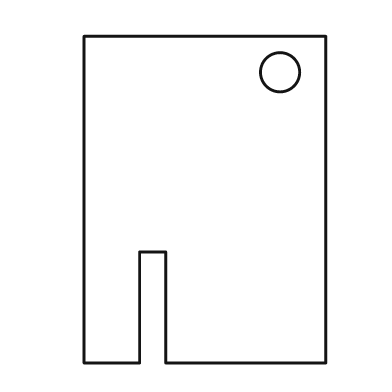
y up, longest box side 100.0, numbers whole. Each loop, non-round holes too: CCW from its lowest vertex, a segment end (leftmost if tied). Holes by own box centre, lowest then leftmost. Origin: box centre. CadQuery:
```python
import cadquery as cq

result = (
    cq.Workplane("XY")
    .moveTo(-37.0, -50.0)
    .lineTo(-20.0, -50.0)
    .lineTo(-20.0, -16.0)
    .lineTo(-12.0, -16.0)
    .lineTo(-12.0, -50.0)
    .lineTo(37.0, -50.0)
    .lineTo(37.0, 50.0)
    .lineTo(-37.0, 50.0)
    .close()
    .moveTo(23.0, 39.0)
    .circle(6.0)
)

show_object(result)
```